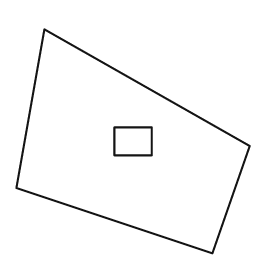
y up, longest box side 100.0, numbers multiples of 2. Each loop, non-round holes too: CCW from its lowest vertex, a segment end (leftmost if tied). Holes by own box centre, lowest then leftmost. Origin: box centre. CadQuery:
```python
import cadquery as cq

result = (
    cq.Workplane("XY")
    .moveTo(34.0, -48.0)
    .lineTo(50.0, -2.0)
    .lineTo(-38.0, 48.0)
    .lineTo(-50.0, -20.0)
    .close()
    .moveTo(-8.0, -6.0)
    .lineTo(8.0, -6.0)
    .lineTo(8.0, 6.0)
    .lineTo(-8.0, 6.0)
    .close()
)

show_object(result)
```